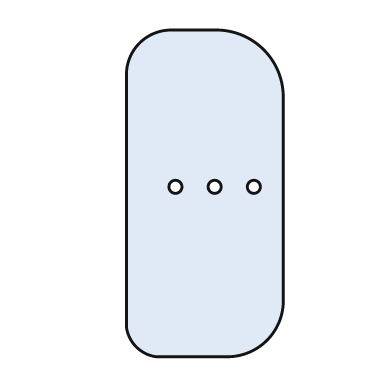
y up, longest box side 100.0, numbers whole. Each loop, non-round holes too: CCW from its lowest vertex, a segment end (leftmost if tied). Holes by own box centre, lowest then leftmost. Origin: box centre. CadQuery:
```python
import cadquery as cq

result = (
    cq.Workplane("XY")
    .moveTo(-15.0, -50.0)
    .lineTo(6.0, -50.0)
    .threePointArc((19.0, -45.0), (24.0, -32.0))
    .lineTo(24.0, 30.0)
    .threePointArc((18.0, 44.0), (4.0, 50.0))
    .lineTo(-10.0, 50.0)
    .threePointArc((-20.0, 46.0), (-24.0, 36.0))
    .lineTo(-24.0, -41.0)
    .threePointArc((-21.0, -47.0), (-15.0, -50.0))
    .close()
    .moveTo(-9.0, 2.0)
    .circle(2.0)
    .moveTo(3.0, 2.0)
    .circle(2.0)
    .moveTo(15.0, 2.0)
    .circle(2.0)
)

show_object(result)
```